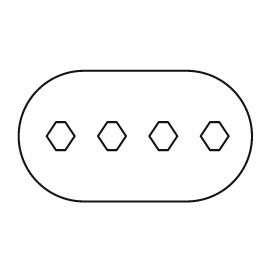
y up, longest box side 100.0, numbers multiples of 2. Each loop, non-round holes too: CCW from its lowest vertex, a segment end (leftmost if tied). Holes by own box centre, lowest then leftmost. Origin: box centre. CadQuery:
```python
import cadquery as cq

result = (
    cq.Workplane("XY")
    .moveTo(-22.0, -28.0)
    .lineTo(22.0, -28.0)
    .threePointArc((50.0, 0.0), (22.0, 28.0))
    .lineTo(-22.0, 28.0)
    .threePointArc((-50.0, 0.0), (-22.0, -28.0))
    .close()
    .moveTo(-34.0, -6.0)
    .lineTo(-30.0, -6.0)
    .lineTo(-26.0, 0.0)
    .lineTo(-30.0, 6.0)
    .lineTo(-34.0, 6.0)
    .lineTo(-38.0, 0.0)
    .close()
    .moveTo(-12.0, -6.0)
    .lineTo(-8.0, -6.0)
    .lineTo(-4.0, 0.0)
    .lineTo(-8.0, 6.0)
    .lineTo(-12.0, 6.0)
    .lineTo(-16.0, 0.0)
    .close()
    .moveTo(10.0, -6.0)
    .lineTo(14.0, -6.0)
    .lineTo(18.0, 0.0)
    .lineTo(14.0, 6.0)
    .lineTo(10.0, 6.0)
    .lineTo(6.0, 0.0)
    .close()
    .moveTo(32.0, -6.0)
    .lineTo(36.0, -6.0)
    .lineTo(40.0, 0.0)
    .lineTo(36.0, 6.0)
    .lineTo(32.0, 6.0)
    .lineTo(28.0, 0.0)
    .close()
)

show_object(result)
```